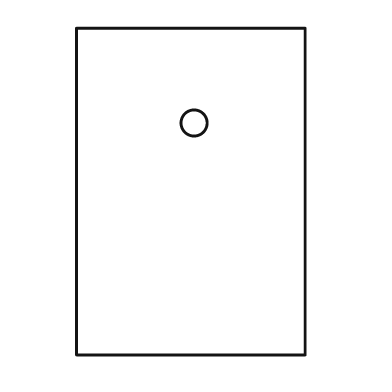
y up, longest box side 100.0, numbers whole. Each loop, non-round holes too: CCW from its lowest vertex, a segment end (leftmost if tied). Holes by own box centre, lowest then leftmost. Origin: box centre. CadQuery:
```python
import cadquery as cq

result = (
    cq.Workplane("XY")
    .moveTo(-35.0, -50.0)
    .lineTo(35.0, -50.0)
    .lineTo(35.0, 50.0)
    .lineTo(-35.0, 50.0)
    .close()
    .moveTo(1.0, 21.0)
    .circle(4.0)
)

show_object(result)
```